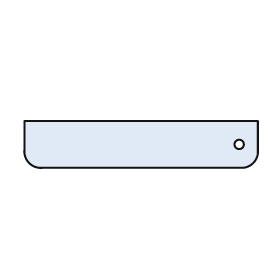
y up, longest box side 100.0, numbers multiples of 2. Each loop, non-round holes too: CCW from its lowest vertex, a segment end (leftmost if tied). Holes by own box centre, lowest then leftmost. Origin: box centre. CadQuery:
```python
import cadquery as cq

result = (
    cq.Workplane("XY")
    .moveTo(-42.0, -10.0)
    .lineTo(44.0, -10.0)
    .threePointArc((48.0, -8.0), (50.0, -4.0))
    .lineTo(50.0, 10.0)
    .lineTo(-50.0, 10.0)
    .lineTo(-50.0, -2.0)
    .threePointArc((-48.0, -8.0), (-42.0, -10.0))
    .close()
    .moveTo(42.0, 0.0)
    .circle(2.0)
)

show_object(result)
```